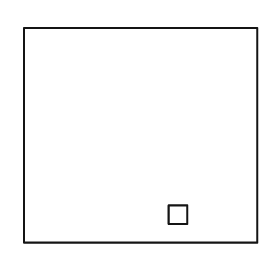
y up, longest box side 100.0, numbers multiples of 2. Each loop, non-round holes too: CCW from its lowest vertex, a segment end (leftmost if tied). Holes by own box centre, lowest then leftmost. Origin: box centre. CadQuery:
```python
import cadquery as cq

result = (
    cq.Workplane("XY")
    .moveTo(-50.0, -46.0)
    .lineTo(50.0, -46.0)
    .lineTo(50.0, 46.0)
    .lineTo(-50.0, 46.0)
    .close()
    .moveTo(12.0, -38.0)
    .lineTo(20.0, -38.0)
    .lineTo(20.0, -30.0)
    .lineTo(12.0, -30.0)
    .close()
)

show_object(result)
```